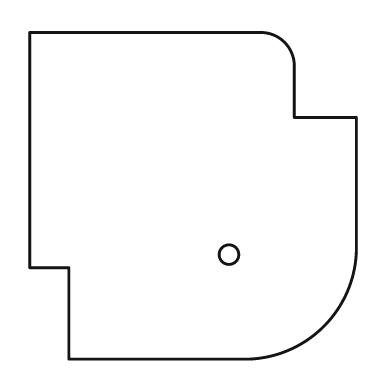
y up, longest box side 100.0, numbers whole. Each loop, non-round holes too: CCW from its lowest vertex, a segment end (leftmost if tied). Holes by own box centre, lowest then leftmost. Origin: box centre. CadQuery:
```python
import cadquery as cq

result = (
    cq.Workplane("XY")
    .moveTo(-38.0, -50.0)
    .lineTo(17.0, -50.0)
    .threePointArc((40.0, -40.0), (50.0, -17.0))
    .lineTo(50.0, 24.0)
    .lineTo(31.0, 24.0)
    .lineTo(31.0, 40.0)
    .threePointArc((28.0, 47.0), (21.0, 50.0))
    .lineTo(-50.0, 50.0)
    .lineTo(-50.0, -22.0)
    .lineTo(-38.0, -22.0)
    .close()
    .moveTo(11.0, -18.0)
    .circle(3.0)
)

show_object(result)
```